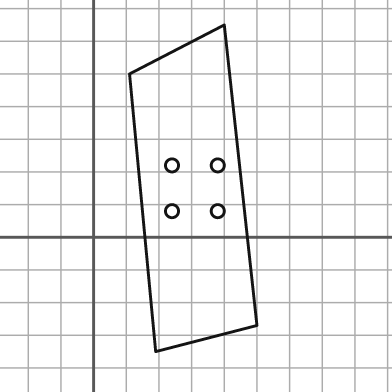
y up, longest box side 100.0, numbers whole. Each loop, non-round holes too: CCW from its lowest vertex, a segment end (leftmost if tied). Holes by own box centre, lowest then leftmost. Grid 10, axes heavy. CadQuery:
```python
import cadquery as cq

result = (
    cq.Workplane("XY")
    .moveTo(19.0, -35.0)
    .lineTo(50.0, -27.0)
    .lineTo(40.0, 65.0)
    .lineTo(11.0, 50.0)
    .close()
    .moveTo(24.0, 8.0)
    .circle(2.0)
    .moveTo(38.0, 8.0)
    .circle(2.0)
    .moveTo(24.0, 22.0)
    .circle(2.0)
    .moveTo(38.0, 22.0)
    .circle(2.0)
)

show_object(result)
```